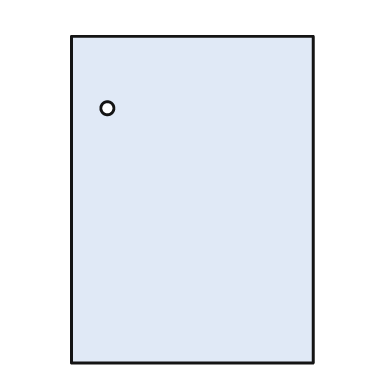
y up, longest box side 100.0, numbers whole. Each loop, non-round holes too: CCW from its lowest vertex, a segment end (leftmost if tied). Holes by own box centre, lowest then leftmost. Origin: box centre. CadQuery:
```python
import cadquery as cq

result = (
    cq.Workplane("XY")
    .moveTo(-37.0, -50.0)
    .lineTo(37.0, -50.0)
    .lineTo(37.0, 50.0)
    .lineTo(-37.0, 50.0)
    .close()
    .moveTo(-26.0, 28.0)
    .circle(2.0)
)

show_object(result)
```